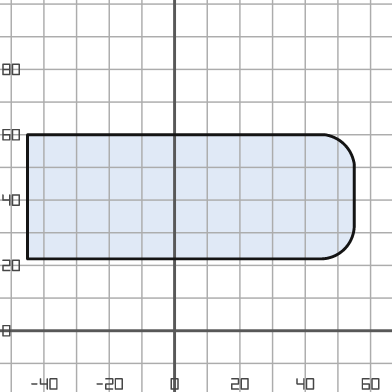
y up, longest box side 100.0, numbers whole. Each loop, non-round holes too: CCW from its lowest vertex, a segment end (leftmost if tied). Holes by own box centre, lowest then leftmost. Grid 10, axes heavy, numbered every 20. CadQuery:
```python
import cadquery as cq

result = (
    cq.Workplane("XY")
    .moveTo(-45.0, 22.0)
    .lineTo(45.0, 22.0)
    .threePointArc((52.0, 25.0), (55.0, 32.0))
    .lineTo(55.0, 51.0)
    .threePointArc((52.0, 57.0), (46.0, 60.0))
    .lineTo(-45.0, 60.0)
    .close()
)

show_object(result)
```